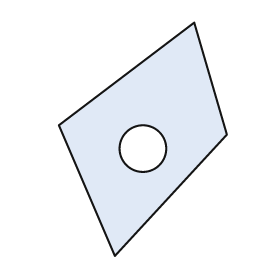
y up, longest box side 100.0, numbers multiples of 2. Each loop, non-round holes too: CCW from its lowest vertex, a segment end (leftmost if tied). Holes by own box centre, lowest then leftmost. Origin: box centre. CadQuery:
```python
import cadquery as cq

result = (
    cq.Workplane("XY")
    .moveTo(-12.0, -50.0)
    .lineTo(36.0, 2.0)
    .lineTo(22.0, 50.0)
    .lineTo(-36.0, 6.0)
    .close()
    .moveTo(0.0, -4.0)
    .circle(10.0)
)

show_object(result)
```